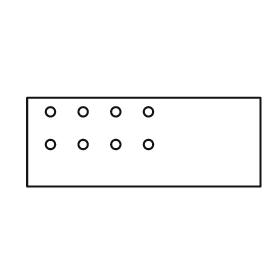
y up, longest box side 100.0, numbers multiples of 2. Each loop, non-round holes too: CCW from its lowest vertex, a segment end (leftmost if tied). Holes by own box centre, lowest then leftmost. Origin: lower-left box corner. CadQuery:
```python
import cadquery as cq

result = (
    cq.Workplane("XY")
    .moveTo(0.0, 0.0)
    .lineTo(100.0, 0.0)
    .lineTo(100.0, 38.0)
    .lineTo(0.0, 38.0)
    .close()
    .moveTo(10.0, 18.0)
    .circle(2.0)
    .moveTo(24.0, 18.0)
    .circle(2.0)
    .moveTo(38.0, 18.0)
    .circle(2.0)
    .moveTo(52.0, 18.0)
    .circle(2.0)
    .moveTo(10.0, 32.0)
    .circle(2.0)
    .moveTo(24.0, 32.0)
    .circle(2.0)
    .moveTo(38.0, 32.0)
    .circle(2.0)
    .moveTo(52.0, 32.0)
    .circle(2.0)
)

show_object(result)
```